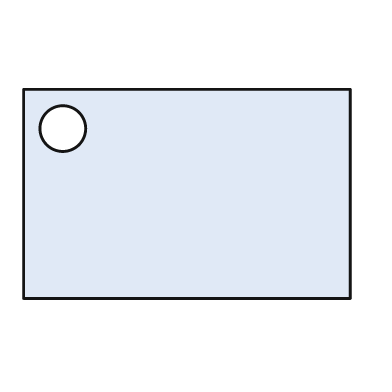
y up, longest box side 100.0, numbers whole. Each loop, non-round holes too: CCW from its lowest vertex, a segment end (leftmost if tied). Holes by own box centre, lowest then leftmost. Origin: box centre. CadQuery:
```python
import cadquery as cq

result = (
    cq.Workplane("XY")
    .moveTo(-50.0, -32.0)
    .lineTo(50.0, -32.0)
    .lineTo(50.0, 32.0)
    .lineTo(-50.0, 32.0)
    .close()
    .moveTo(-38.0, 20.0)
    .circle(7.0)
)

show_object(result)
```